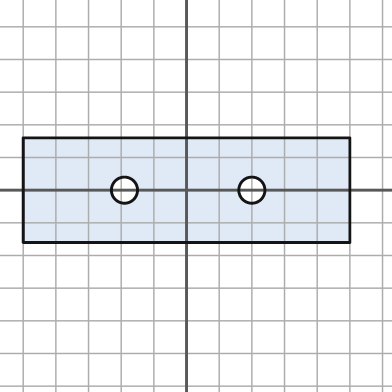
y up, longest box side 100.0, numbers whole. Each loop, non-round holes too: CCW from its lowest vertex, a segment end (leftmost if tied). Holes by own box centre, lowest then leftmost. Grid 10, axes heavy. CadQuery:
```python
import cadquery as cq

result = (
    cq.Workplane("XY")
    .moveTo(-50.0, -16.0)
    .lineTo(50.0, -16.0)
    .lineTo(50.0, 16.0)
    .lineTo(-50.0, 16.0)
    .close()
    .moveTo(-19.0, 0.0)
    .circle(4.0)
    .moveTo(20.0, 0.0)
    .circle(4.0)
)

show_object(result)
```